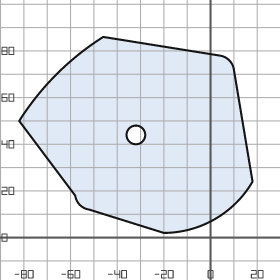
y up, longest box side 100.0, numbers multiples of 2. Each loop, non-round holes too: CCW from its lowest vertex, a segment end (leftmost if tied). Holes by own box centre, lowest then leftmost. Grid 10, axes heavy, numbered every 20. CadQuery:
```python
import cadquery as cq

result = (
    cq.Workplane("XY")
    .moveTo(-20.0, 2.0)
    .threePointArc((2.0, 8.0), (18.0, 24.0))
    .lineTo(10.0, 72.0)
    .threePointArc((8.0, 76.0), (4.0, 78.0))
    .lineTo(-46.0, 86.0)
    .threePointArc((-66.0, 70.0), (-82.0, 50.0))
    .lineTo(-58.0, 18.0)
    .threePointArc((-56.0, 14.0), (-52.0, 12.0))
    .close()
    .moveTo(-32.0, 44.0)
    .circle(4.0)
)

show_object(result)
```